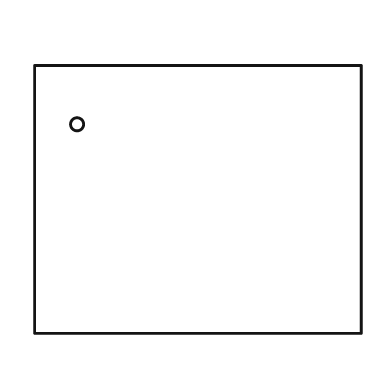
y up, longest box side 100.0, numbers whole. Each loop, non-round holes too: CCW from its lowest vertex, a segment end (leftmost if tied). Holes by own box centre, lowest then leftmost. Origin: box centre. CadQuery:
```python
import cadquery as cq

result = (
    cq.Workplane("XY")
    .moveTo(-50.0, -41.0)
    .lineTo(50.0, -41.0)
    .lineTo(50.0, 41.0)
    .lineTo(-50.0, 41.0)
    .close()
    .moveTo(-37.0, 23.0)
    .circle(2.0)
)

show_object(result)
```